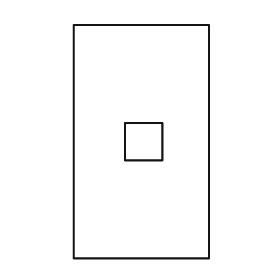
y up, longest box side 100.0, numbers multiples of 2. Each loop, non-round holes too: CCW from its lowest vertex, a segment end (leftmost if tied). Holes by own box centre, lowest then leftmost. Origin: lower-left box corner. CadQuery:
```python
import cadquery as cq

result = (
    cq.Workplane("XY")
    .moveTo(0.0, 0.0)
    .lineTo(58.0, 0.0)
    .lineTo(58.0, 100.0)
    .lineTo(0.0, 100.0)
    .close()
    .moveTo(22.0, 42.0)
    .lineTo(38.0, 42.0)
    .lineTo(38.0, 58.0)
    .lineTo(22.0, 58.0)
    .close()
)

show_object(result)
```